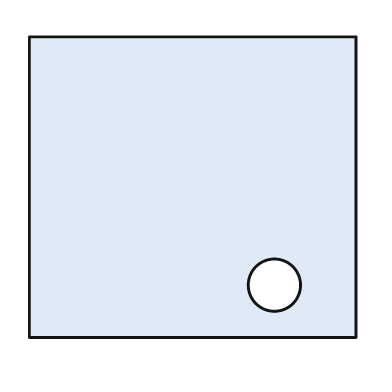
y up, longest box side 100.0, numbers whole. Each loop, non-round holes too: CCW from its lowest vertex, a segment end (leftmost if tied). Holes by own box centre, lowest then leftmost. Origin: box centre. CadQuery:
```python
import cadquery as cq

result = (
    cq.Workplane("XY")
    .moveTo(-50.0, -46.0)
    .lineTo(50.0, -46.0)
    .lineTo(50.0, 46.0)
    .lineTo(-50.0, 46.0)
    .close()
    .moveTo(25.0, -30.0)
    .circle(8.0)
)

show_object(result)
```